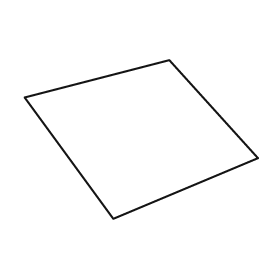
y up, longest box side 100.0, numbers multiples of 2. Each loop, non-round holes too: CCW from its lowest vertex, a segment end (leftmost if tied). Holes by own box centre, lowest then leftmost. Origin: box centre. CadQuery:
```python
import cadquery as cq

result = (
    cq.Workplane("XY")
    .moveTo(-12.0, -34.0)
    .lineTo(50.0, -8.0)
    .lineTo(12.0, 34.0)
    .lineTo(-50.0, 18.0)
    .close()
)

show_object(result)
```